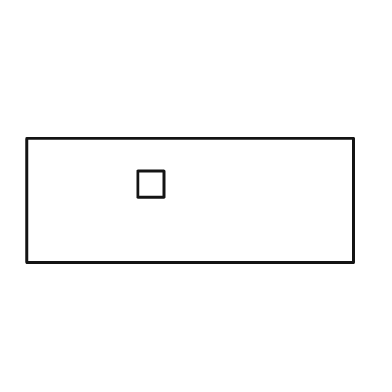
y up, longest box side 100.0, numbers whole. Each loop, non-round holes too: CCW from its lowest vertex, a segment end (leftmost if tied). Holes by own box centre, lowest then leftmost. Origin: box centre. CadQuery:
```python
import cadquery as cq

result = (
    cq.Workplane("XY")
    .moveTo(-50.0, -19.0)
    .lineTo(50.0, -19.0)
    .lineTo(50.0, 19.0)
    .lineTo(-50.0, 19.0)
    .close()
    .moveTo(-16.0, 1.0)
    .lineTo(-8.0, 1.0)
    .lineTo(-8.0, 9.0)
    .lineTo(-16.0, 9.0)
    .close()
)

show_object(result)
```